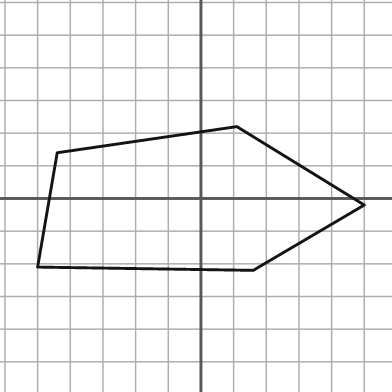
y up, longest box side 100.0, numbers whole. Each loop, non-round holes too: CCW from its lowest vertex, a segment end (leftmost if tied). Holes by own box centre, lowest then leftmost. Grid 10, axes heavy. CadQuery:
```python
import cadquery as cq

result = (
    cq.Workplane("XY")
    .moveTo(16.0, -22.0)
    .lineTo(50.0, -2.0)
    .lineTo(11.0, 22.0)
    .lineTo(-44.0, 14.0)
    .lineTo(-50.0, -21.0)
    .close()
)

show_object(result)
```